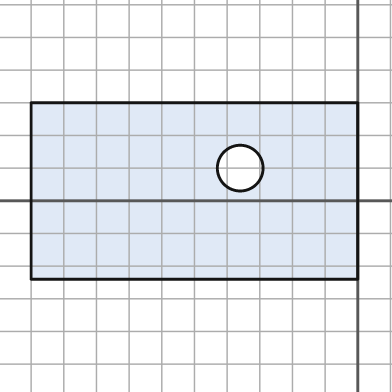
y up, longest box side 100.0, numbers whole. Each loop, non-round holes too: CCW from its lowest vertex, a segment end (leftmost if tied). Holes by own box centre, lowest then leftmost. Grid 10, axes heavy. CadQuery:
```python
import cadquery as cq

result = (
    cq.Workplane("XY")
    .moveTo(-100.0, -24.0)
    .lineTo(0.0, -24.0)
    .lineTo(0.0, 30.0)
    .lineTo(-100.0, 30.0)
    .close()
    .moveTo(-36.0, 10.0)
    .circle(7.0)
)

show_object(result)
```